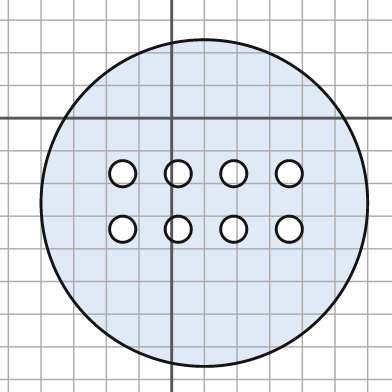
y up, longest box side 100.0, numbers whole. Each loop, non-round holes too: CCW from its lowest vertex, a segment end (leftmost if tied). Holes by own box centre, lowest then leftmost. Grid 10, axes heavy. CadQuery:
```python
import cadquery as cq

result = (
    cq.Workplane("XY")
    .moveTo(10.0, -26.0)
    .circle(50.0)
    .moveTo(-15.0, -34.0)
    .circle(4.0)
    .moveTo(2.0, -34.0)
    .circle(4.0)
    .moveTo(19.0, -34.0)
    .circle(4.0)
    .moveTo(36.0, -34.0)
    .circle(4.0)
    .moveTo(-15.0, -17.0)
    .circle(4.0)
    .moveTo(2.0, -17.0)
    .circle(4.0)
    .moveTo(19.0, -17.0)
    .circle(4.0)
    .moveTo(36.0, -17.0)
    .circle(4.0)
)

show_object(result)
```